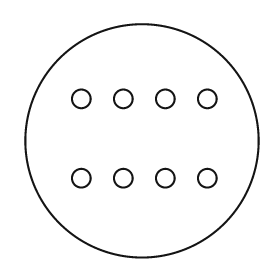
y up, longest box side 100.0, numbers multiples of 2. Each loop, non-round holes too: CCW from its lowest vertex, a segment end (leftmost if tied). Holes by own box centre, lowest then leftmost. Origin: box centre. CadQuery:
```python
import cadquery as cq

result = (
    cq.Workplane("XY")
    .moveTo(0.0, 0.0)
    .circle(50.0)
    .moveTo(-26.0, -16.0)
    .circle(4.0)
    .moveTo(-8.0, -16.0)
    .circle(4.0)
    .moveTo(10.0, -16.0)
    .circle(4.0)
    .moveTo(28.0, -16.0)
    .circle(4.0)
    .moveTo(-26.0, 18.0)
    .circle(4.0)
    .moveTo(-8.0, 18.0)
    .circle(4.0)
    .moveTo(10.0, 18.0)
    .circle(4.0)
    .moveTo(28.0, 18.0)
    .circle(4.0)
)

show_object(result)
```